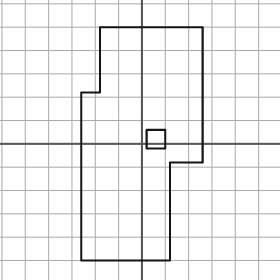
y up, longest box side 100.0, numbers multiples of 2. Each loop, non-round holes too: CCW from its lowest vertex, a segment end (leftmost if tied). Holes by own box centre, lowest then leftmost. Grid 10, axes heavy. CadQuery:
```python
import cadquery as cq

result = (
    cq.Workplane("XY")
    .moveTo(-26.0, -50.0)
    .lineTo(12.0, -50.0)
    .lineTo(12.0, -8.0)
    .lineTo(26.0, -8.0)
    .lineTo(26.0, 50.0)
    .lineTo(-18.0, 50.0)
    .lineTo(-18.0, 22.0)
    .lineTo(-26.0, 22.0)
    .close()
    .moveTo(2.0, -2.0)
    .lineTo(10.0, -2.0)
    .lineTo(10.0, 6.0)
    .lineTo(2.0, 6.0)
    .close()
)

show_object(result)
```